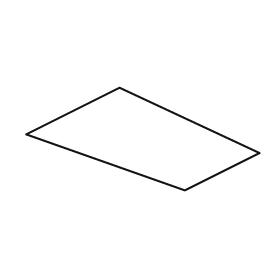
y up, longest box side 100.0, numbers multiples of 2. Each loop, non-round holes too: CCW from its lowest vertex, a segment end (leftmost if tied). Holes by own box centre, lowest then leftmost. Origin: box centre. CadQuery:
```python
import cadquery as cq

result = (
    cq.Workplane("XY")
    .moveTo(18.0, -22.0)
    .lineTo(50.0, -6.0)
    .lineTo(-10.0, 22.0)
    .lineTo(-50.0, 2.0)
    .close()
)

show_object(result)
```